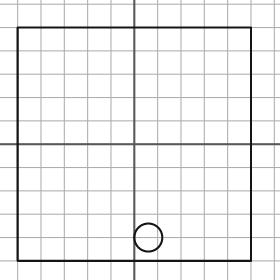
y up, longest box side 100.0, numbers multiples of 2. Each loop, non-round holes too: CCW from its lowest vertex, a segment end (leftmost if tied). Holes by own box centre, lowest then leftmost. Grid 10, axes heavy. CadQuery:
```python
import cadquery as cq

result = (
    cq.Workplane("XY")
    .moveTo(-50.0, -50.0)
    .lineTo(50.0, -50.0)
    .lineTo(50.0, 50.0)
    .lineTo(-50.0, 50.0)
    .close()
    .moveTo(6.0, -40.0)
    .circle(6.0)
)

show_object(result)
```